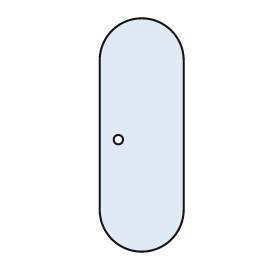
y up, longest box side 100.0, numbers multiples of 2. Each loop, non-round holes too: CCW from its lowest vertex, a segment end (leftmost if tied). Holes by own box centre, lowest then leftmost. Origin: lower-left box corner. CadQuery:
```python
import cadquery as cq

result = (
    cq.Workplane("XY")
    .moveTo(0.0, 18.0)
    .threePointArc((18.0, 0.0), (36.0, 18.0))
    .lineTo(36.0, 82.0)
    .threePointArc((18.0, 100.0), (0.0, 82.0))
    .close()
    .moveTo(8.0, 48.0)
    .circle(2.0)
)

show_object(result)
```